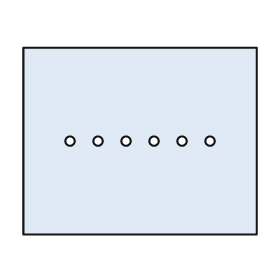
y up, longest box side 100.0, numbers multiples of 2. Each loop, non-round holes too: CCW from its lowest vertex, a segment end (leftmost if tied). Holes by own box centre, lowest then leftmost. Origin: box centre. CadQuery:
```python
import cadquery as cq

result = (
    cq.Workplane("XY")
    .moveTo(-50.0, -40.0)
    .lineTo(50.0, -40.0)
    .lineTo(50.0, 40.0)
    .lineTo(-50.0, 40.0)
    .close()
    .moveTo(-30.0, 0.0)
    .circle(2.0)
    .moveTo(-18.0, 0.0)
    .circle(2.0)
    .moveTo(-6.0, 0.0)
    .circle(2.0)
    .moveTo(6.0, 0.0)
    .circle(2.0)
    .moveTo(18.0, 0.0)
    .circle(2.0)
    .moveTo(30.0, 0.0)
    .circle(2.0)
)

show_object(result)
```